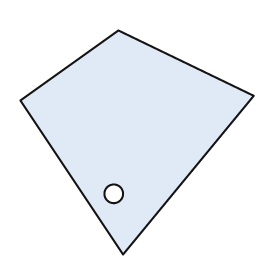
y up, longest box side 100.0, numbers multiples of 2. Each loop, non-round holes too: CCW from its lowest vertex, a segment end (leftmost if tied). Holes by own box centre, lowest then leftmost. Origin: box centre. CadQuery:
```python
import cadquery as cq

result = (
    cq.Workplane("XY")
    .moveTo(-6.0, -48.0)
    .lineTo(50.0, 20.0)
    .lineTo(-8.0, 48.0)
    .lineTo(-50.0, 18.0)
    .close()
    .moveTo(-10.0, -22.0)
    .circle(4.0)
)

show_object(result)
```